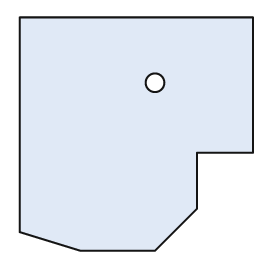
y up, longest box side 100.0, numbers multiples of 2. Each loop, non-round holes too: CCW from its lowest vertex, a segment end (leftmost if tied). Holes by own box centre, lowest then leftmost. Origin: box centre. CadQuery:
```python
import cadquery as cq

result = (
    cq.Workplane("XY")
    .moveTo(-24.0, -50.0)
    .lineTo(8.0, -50.0)
    .lineTo(26.0, -32.0)
    .lineTo(26.0, -8.0)
    .lineTo(50.0, -8.0)
    .lineTo(50.0, 50.0)
    .lineTo(-50.0, 50.0)
    .lineTo(-50.0, -42.0)
    .close()
    .moveTo(8.0, 22.0)
    .circle(4.0)
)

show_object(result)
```